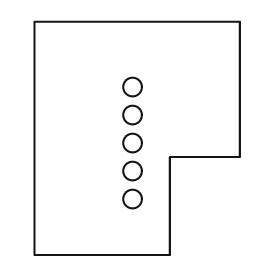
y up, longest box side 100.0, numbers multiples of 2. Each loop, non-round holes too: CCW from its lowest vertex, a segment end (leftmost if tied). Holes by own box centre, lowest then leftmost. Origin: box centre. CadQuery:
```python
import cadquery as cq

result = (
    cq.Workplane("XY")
    .moveTo(-44.0, -50.0)
    .lineTo(14.0, -50.0)
    .lineTo(14.0, -8.0)
    .lineTo(44.0, -8.0)
    .lineTo(44.0, 50.0)
    .lineTo(-44.0, 50.0)
    .close()
    .moveTo(-2.0, -26.0)
    .circle(4.0)
    .moveTo(-2.0, -14.0)
    .circle(4.0)
    .moveTo(-2.0, -2.0)
    .circle(4.0)
    .moveTo(-2.0, 10.0)
    .circle(4.0)
    .moveTo(-2.0, 22.0)
    .circle(4.0)
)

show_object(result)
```